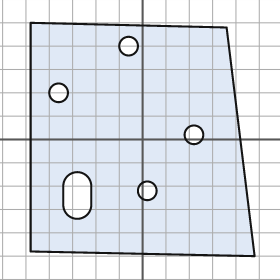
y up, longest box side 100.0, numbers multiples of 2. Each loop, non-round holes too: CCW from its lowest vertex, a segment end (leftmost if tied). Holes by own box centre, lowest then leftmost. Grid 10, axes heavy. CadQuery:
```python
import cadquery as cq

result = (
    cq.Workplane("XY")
    .moveTo(48.0, -50.0)
    .lineTo(36.0, 48.0)
    .lineTo(-48.0, 50.0)
    .lineTo(-48.0, -48.0)
    .close()
    .moveTo(-34.0, -28.0)
    .threePointArc((-28.0, -34.0), (-22.0, -28.0))
    .lineTo(-22.0, -20.0)
    .threePointArc((-28.0, -14.0), (-34.0, -20.0))
    .close()
    .moveTo(2.0, -22.0)
    .circle(4.0)
    .moveTo(22.0, 2.0)
    .circle(4.0)
    .moveTo(-36.0, 20.0)
    .circle(4.0)
    .moveTo(-6.0, 40.0)
    .circle(4.0)
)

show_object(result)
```